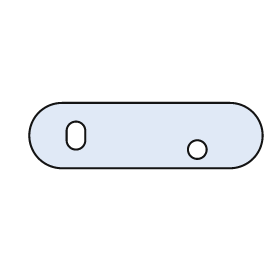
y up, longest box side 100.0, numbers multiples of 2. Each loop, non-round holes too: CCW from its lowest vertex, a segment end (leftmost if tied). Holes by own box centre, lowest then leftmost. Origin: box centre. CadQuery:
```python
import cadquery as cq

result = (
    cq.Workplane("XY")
    .moveTo(-36.0, -14.0)
    .lineTo(36.0, -14.0)
    .threePointArc((50.0, 0.0), (36.0, 14.0))
    .lineTo(-36.0, 14.0)
    .threePointArc((-50.0, 0.0), (-36.0, -14.0))
    .close()
    .moveTo(22.0, -6.0)
    .circle(4.0)
    .moveTo(-34.0, -2.0)
    .threePointArc((-30.0, -6.0), (-26.0, -2.0))
    .lineTo(-26.0, 2.0)
    .threePointArc((-30.0, 6.0), (-34.0, 2.0))
    .close()
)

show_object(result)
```